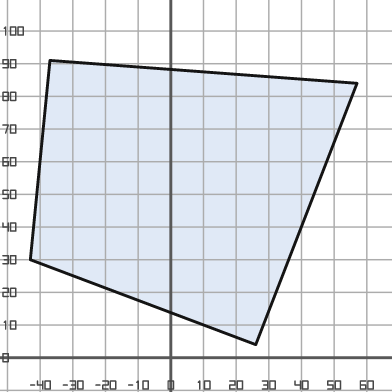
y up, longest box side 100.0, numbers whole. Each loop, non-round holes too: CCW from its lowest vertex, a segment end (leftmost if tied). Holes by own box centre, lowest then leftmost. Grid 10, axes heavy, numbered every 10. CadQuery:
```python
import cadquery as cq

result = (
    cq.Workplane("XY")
    .moveTo(26.0, 4.0)
    .lineTo(57.0, 84.0)
    .lineTo(-37.0, 91.0)
    .lineTo(-43.0, 30.0)
    .close()
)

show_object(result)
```